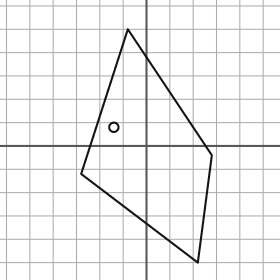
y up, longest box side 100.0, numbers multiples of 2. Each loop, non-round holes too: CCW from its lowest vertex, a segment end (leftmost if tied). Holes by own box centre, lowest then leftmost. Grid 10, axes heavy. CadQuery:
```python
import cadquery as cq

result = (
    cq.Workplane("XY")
    .moveTo(22.0, -50.0)
    .lineTo(28.0, -4.0)
    .lineTo(-8.0, 50.0)
    .lineTo(-28.0, -12.0)
    .close()
    .moveTo(-14.0, 8.0)
    .circle(2.0)
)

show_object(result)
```